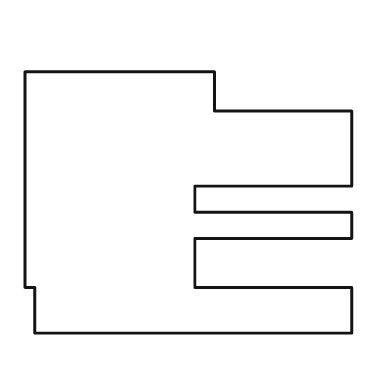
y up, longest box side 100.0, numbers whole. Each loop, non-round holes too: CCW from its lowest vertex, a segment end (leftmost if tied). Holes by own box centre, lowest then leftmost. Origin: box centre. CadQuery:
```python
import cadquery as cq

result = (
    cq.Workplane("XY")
    .moveTo(-47.0, -40.0)
    .lineTo(50.0, -40.0)
    .lineTo(50.0, -26.0)
    .lineTo(2.0, -26.0)
    .lineTo(2.0, -11.0)
    .lineTo(50.0, -11.0)
    .lineTo(50.0, -3.0)
    .lineTo(2.0, -3.0)
    .lineTo(2.0, 5.0)
    .lineTo(50.0, 5.0)
    .lineTo(50.0, 28.0)
    .lineTo(8.0, 28.0)
    .lineTo(8.0, 40.0)
    .lineTo(-50.0, 40.0)
    .lineTo(-50.0, -26.0)
    .lineTo(-47.0, -26.0)
    .close()
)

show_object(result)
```